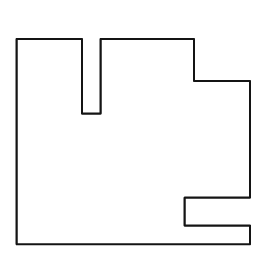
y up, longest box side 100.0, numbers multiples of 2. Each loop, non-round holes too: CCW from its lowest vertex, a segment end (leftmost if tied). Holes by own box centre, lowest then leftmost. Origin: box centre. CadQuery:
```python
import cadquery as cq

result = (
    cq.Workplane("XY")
    .moveTo(-50.0, -44.0)
    .lineTo(50.0, -44.0)
    .lineTo(50.0, -36.0)
    .lineTo(22.0, -36.0)
    .lineTo(22.0, -24.0)
    .lineTo(50.0, -24.0)
    .lineTo(50.0, 26.0)
    .lineTo(26.0, 26.0)
    .lineTo(26.0, 44.0)
    .lineTo(-14.0, 44.0)
    .lineTo(-14.0, 12.0)
    .lineTo(-22.0, 12.0)
    .lineTo(-22.0, 44.0)
    .lineTo(-50.0, 44.0)
    .close()
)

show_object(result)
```